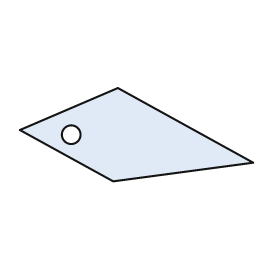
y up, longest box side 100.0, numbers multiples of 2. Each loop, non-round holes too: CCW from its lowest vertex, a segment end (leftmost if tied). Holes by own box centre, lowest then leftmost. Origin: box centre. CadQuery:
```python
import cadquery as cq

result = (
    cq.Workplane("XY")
    .moveTo(-10.0, -20.0)
    .lineTo(50.0, -12.0)
    .lineTo(-8.0, 20.0)
    .lineTo(-50.0, 2.0)
    .close()
    .moveTo(-28.0, 0.0)
    .circle(4.0)
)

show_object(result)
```